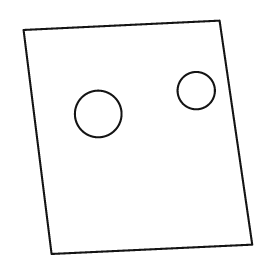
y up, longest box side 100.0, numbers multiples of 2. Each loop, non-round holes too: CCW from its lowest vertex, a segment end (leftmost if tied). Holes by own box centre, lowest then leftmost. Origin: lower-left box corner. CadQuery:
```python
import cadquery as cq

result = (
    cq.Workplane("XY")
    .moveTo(12.0, 0.0)
    .lineTo(98.0, 4.0)
    .lineTo(84.0, 100.0)
    .lineTo(0.0, 96.0)
    .close()
    .moveTo(32.0, 60.0)
    .circle(10.0)
    .moveTo(74.0, 70.0)
    .circle(8.0)
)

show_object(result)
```